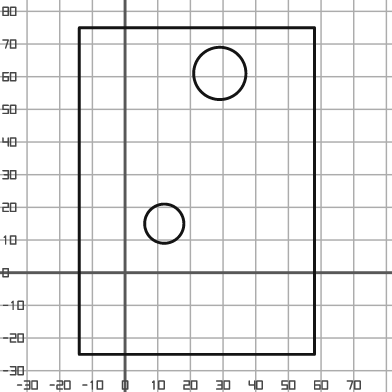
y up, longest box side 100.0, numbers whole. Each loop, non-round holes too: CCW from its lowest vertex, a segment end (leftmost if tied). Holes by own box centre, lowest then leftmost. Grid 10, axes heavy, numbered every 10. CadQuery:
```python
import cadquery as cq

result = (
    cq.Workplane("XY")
    .moveTo(-14.0, -25.0)
    .lineTo(58.0, -25.0)
    .lineTo(58.0, 75.0)
    .lineTo(-14.0, 75.0)
    .close()
    .moveTo(12.0, 15.0)
    .circle(6.0)
    .moveTo(29.0, 61.0)
    .circle(8.0)
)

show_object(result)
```